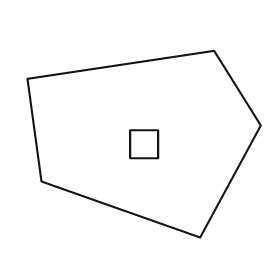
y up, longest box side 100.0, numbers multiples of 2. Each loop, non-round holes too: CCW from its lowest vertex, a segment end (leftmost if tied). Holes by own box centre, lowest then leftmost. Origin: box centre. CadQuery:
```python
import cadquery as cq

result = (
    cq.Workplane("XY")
    .moveTo(24.0, -40.0)
    .lineTo(50.0, 8.0)
    .lineTo(30.0, 40.0)
    .lineTo(-50.0, 28.0)
    .lineTo(-44.0, -16.0)
    .close()
    .moveTo(-6.0, -6.0)
    .lineTo(6.0, -6.0)
    .lineTo(6.0, 6.0)
    .lineTo(-6.0, 6.0)
    .close()
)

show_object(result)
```